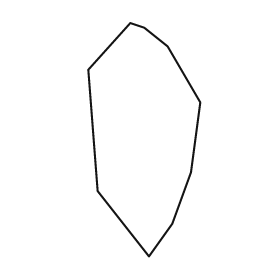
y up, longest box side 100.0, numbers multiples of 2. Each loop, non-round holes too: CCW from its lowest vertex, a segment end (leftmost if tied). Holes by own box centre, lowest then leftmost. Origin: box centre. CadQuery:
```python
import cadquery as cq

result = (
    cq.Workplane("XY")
    .moveTo(2.0, -50.0)
    .lineTo(12.0, -36.0)
    .lineTo(20.0, -14.0)
    .lineTo(24.0, 16.0)
    .lineTo(10.0, 40.0)
    .lineTo(0.0, 48.0)
    .lineTo(-6.0, 50.0)
    .lineTo(-24.0, 30.0)
    .lineTo(-20.0, -22.0)
    .close()
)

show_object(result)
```